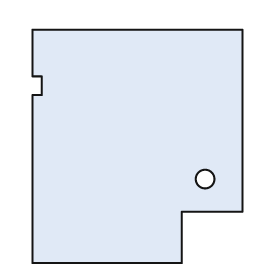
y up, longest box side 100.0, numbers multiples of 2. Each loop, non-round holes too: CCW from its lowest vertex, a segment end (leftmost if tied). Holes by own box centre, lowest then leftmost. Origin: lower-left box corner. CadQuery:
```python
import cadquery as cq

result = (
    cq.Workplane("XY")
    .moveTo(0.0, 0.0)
    .lineTo(64.0, 0.0)
    .lineTo(64.0, 22.0)
    .lineTo(90.0, 22.0)
    .lineTo(90.0, 100.0)
    .lineTo(0.0, 100.0)
    .lineTo(0.0, 80.0)
    .lineTo(4.0, 80.0)
    .lineTo(4.0, 72.0)
    .lineTo(0.0, 72.0)
    .close()
    .moveTo(74.0, 36.0)
    .circle(4.0)
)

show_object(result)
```